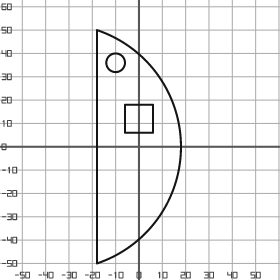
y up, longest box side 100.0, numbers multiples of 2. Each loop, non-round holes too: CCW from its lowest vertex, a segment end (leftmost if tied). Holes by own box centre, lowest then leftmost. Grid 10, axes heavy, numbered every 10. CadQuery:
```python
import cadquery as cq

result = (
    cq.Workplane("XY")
    .moveTo(-18.0, -50.0)
    .threePointArc((18.0, 0.0), (-18.0, 50.0))
    .close()
    .moveTo(-6.0, 6.0)
    .lineTo(6.0, 6.0)
    .lineTo(6.0, 18.0)
    .lineTo(-6.0, 18.0)
    .close()
    .moveTo(-10.0, 36.0)
    .circle(4.0)
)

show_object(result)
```